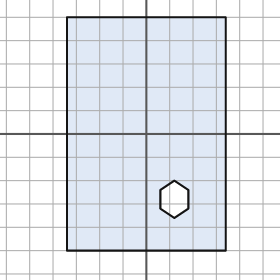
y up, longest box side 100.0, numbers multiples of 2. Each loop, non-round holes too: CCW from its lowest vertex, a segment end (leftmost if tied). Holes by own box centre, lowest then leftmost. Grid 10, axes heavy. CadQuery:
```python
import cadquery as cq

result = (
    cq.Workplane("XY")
    .moveTo(-34.0, -50.0)
    .lineTo(34.0, -50.0)
    .lineTo(34.0, 50.0)
    .lineTo(-34.0, 50.0)
    .close()
    .moveTo(12.0, -36.0)
    .lineTo(18.0, -32.0)
    .lineTo(18.0, -24.0)
    .lineTo(12.0, -20.0)
    .lineTo(6.0, -24.0)
    .lineTo(6.0, -32.0)
    .close()
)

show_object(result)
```